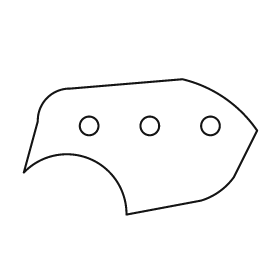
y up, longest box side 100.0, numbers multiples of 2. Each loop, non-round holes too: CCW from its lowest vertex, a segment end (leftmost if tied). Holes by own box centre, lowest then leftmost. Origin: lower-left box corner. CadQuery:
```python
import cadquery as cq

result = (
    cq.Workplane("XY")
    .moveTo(44.0, 0.0)
    .lineTo(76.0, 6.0)
    .threePointArc((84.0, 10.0), (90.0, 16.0))
    .lineTo(100.0, 36.0)
    .threePointArc((86.0, 50.0), (68.0, 58.0))
    .lineTo(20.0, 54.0)
    .threePointArc((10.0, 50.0), (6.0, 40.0))
    .lineTo(0.0, 18.0)
    .threePointArc((28.0, 24.0), (44.0, 0.0))
    .close()
    .moveTo(28.0, 38.0)
    .circle(4.0)
    .moveTo(54.0, 38.0)
    .circle(4.0)
    .moveTo(80.0, 38.0)
    .circle(4.0)
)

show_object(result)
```